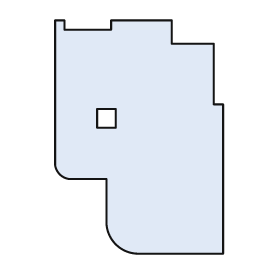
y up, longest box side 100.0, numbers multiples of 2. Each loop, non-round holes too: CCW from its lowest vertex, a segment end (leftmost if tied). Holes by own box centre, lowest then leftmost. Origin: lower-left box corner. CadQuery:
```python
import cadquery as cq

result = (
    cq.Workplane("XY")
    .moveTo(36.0, 0.0)
    .lineTo(72.0, 0.0)
    .lineTo(72.0, 64.0)
    .lineTo(68.0, 64.0)
    .lineTo(68.0, 90.0)
    .lineTo(50.0, 90.0)
    .lineTo(50.0, 100.0)
    .lineTo(24.0, 100.0)
    .lineTo(24.0, 96.0)
    .lineTo(4.0, 96.0)
    .lineTo(4.0, 100.0)
    .lineTo(0.0, 100.0)
    .lineTo(0.0, 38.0)
    .threePointArc((2.0, 34.0), (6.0, 32.0))
    .lineTo(22.0, 32.0)
    .lineTo(22.0, 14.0)
    .threePointArc((26.0, 4.0), (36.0, 0.0))
    .close()
    .moveTo(18.0, 54.0)
    .lineTo(26.0, 54.0)
    .lineTo(26.0, 62.0)
    .lineTo(18.0, 62.0)
    .close()
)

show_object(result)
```